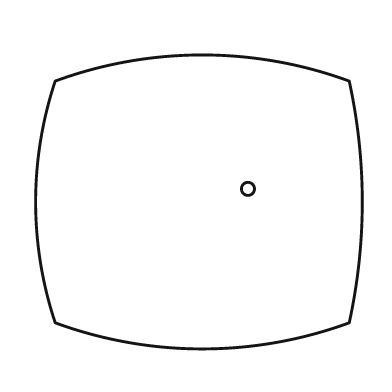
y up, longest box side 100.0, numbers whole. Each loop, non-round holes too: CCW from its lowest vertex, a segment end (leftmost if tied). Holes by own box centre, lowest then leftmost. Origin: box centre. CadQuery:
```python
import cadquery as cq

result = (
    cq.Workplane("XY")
    .moveTo(-44.0, -37.0)
    .threePointArc((1.0, -45.0), (46.0, -37.0))
    .threePointArc((50.0, 0.0), (46.0, 37.0))
    .threePointArc((1.0, 45.0), (-44.0, 37.0))
    .threePointArc((-50.0, 0.0), (-44.0, -37.0))
    .close()
    .moveTo(15.0, 4.0)
    .circle(2.0)
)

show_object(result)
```